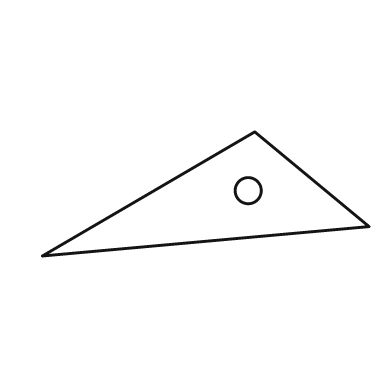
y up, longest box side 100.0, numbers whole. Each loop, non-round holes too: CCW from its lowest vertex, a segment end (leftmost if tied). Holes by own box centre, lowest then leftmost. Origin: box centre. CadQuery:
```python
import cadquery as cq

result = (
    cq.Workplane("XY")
    .moveTo(-50.0, -19.0)
    .lineTo(50.0, -10.0)
    .lineTo(15.0, 19.0)
    .close()
    .moveTo(13.0, 1.0)
    .circle(4.0)
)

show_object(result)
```